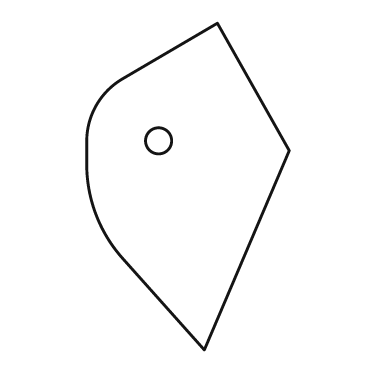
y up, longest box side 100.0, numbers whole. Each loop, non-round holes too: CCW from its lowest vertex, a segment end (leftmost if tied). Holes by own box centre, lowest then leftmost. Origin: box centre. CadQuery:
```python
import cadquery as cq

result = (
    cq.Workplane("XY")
    .moveTo(5.0, -50.0)
    .lineTo(31.0, 11.0)
    .lineTo(9.0, 50.0)
    .lineTo(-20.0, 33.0)
    .threePointArc((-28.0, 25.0), (-31.0, 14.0))
    .lineTo(-31.0, 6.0)
    .threePointArc((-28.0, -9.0), (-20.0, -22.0))
    .close()
    .moveTo(-9.0, 14.0)
    .circle(4.0)
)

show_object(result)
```